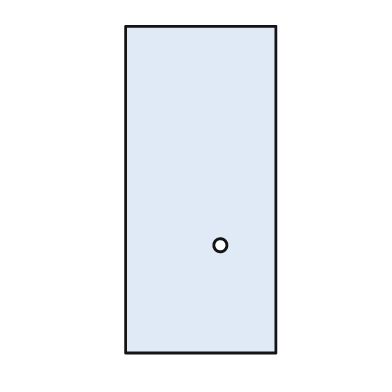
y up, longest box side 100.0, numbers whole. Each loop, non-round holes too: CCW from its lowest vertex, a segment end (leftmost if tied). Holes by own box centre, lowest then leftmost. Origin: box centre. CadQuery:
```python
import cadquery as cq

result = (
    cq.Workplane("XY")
    .moveTo(-23.0, -50.0)
    .lineTo(23.0, -50.0)
    .lineTo(23.0, 50.0)
    .lineTo(-23.0, 50.0)
    .close()
    .moveTo(6.0, -17.0)
    .circle(2.0)
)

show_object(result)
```